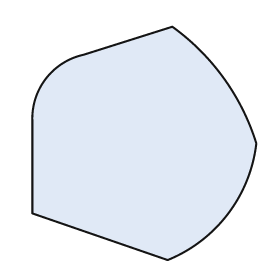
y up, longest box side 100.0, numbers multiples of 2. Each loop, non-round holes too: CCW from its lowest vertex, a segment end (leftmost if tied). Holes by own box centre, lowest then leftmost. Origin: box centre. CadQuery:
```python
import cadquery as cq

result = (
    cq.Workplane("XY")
    .moveTo(10.0, -50.0)
    .threePointArc((36.0, -30.0), (48.0, 0.0))
    .threePointArc((34.0, 28.0), (12.0, 50.0))
    .lineTo(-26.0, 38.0)
    .threePointArc((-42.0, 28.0), (-48.0, 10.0))
    .lineTo(-48.0, -30.0)
    .close()
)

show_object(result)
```